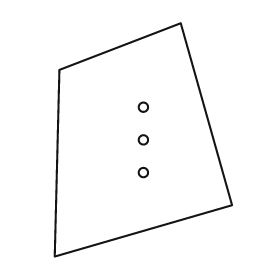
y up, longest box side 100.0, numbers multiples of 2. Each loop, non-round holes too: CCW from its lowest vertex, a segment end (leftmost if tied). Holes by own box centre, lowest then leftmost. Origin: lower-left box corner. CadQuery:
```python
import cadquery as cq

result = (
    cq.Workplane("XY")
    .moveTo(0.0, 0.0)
    .lineTo(76.0, 22.0)
    .lineTo(54.0, 100.0)
    .lineTo(2.0, 80.0)
    .close()
    .moveTo(38.0, 36.0)
    .circle(2.0)
    .moveTo(38.0, 50.0)
    .circle(2.0)
    .moveTo(38.0, 64.0)
    .circle(2.0)
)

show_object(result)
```